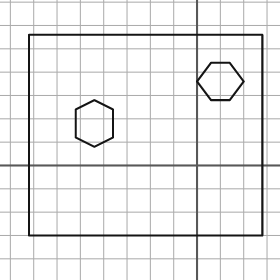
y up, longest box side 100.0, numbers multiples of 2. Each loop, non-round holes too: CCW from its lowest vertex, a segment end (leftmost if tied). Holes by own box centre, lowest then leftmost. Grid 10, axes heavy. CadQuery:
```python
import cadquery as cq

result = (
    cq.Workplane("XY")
    .moveTo(-72.0, -30.0)
    .lineTo(28.0, -30.0)
    .lineTo(28.0, 56.0)
    .lineTo(-72.0, 56.0)
    .close()
    .moveTo(-44.0, 8.0)
    .lineTo(-36.0, 12.0)
    .lineTo(-36.0, 24.0)
    .lineTo(-44.0, 28.0)
    .lineTo(-52.0, 24.0)
    .lineTo(-52.0, 12.0)
    .close()
    .moveTo(6.0, 28.0)
    .lineTo(14.0, 28.0)
    .lineTo(20.0, 36.0)
    .lineTo(14.0, 44.0)
    .lineTo(6.0, 44.0)
    .lineTo(0.0, 36.0)
    .close()
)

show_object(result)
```